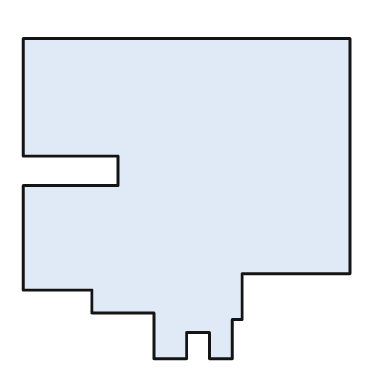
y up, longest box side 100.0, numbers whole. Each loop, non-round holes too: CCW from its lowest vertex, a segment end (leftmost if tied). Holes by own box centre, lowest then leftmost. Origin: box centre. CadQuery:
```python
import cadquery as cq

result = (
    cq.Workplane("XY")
    .moveTo(-10.0, -49.0)
    .lineTo(0.0, -49.0)
    .lineTo(0.0, -41.0)
    .lineTo(7.0, -41.0)
    .lineTo(7.0, -49.0)
    .lineTo(14.0, -49.0)
    .lineTo(14.0, -37.0)
    .lineTo(17.0, -37.0)
    .lineTo(17.0, -23.0)
    .lineTo(50.0, -23.0)
    .lineTo(50.0, 49.0)
    .lineTo(-50.0, 49.0)
    .lineTo(-50.0, 13.0)
    .lineTo(-21.0, 13.0)
    .lineTo(-21.0, 4.0)
    .lineTo(-50.0, 4.0)
    .lineTo(-50.0, -28.0)
    .lineTo(-29.0, -28.0)
    .lineTo(-29.0, -35.0)
    .lineTo(-10.0, -35.0)
    .close()
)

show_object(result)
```